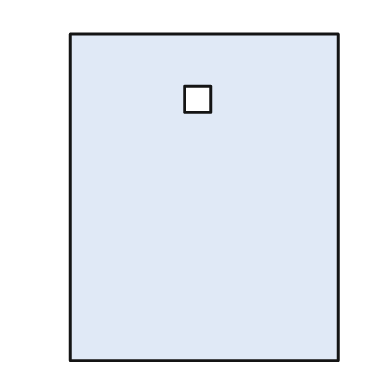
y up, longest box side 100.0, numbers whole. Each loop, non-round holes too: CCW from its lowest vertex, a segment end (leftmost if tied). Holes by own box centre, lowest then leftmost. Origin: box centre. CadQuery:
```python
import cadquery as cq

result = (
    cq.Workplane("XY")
    .moveTo(-41.0, -50.0)
    .lineTo(41.0, -50.0)
    .lineTo(41.0, 50.0)
    .lineTo(-41.0, 50.0)
    .close()
    .moveTo(-6.0, 26.0)
    .lineTo(2.0, 26.0)
    .lineTo(2.0, 34.0)
    .lineTo(-6.0, 34.0)
    .close()
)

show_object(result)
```